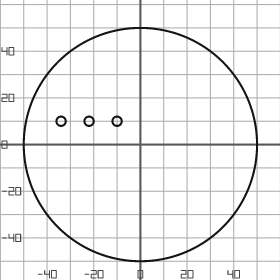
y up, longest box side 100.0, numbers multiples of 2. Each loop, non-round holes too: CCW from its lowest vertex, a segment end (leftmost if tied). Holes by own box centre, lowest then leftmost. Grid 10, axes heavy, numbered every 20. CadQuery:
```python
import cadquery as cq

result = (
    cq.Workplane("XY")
    .moveTo(0.0, 0.0)
    .circle(50.0)
    .moveTo(-34.0, 10.0)
    .circle(2.0)
    .moveTo(-22.0, 10.0)
    .circle(2.0)
    .moveTo(-10.0, 10.0)
    .circle(2.0)
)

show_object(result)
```